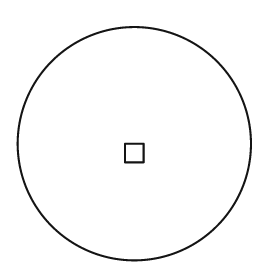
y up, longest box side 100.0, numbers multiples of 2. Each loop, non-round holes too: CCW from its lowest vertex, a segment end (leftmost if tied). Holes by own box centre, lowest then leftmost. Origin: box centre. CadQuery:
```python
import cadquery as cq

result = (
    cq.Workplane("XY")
    .moveTo(0.0, 0.0)
    .circle(50.0)
    .moveTo(-4.0, -8.0)
    .lineTo(4.0, -8.0)
    .lineTo(4.0, 0.0)
    .lineTo(-4.0, 0.0)
    .close()
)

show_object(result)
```